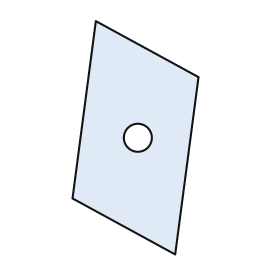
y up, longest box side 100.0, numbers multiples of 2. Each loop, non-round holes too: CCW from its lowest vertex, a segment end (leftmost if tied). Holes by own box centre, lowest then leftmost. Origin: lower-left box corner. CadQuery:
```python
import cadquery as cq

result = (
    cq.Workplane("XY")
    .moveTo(44.0, 0.0)
    .lineTo(54.0, 76.0)
    .lineTo(10.0, 100.0)
    .lineTo(0.0, 24.0)
    .close()
    .moveTo(28.0, 50.0)
    .circle(6.0)
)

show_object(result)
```